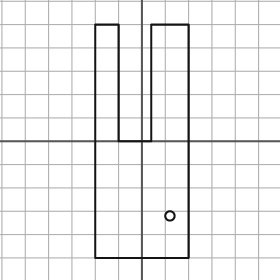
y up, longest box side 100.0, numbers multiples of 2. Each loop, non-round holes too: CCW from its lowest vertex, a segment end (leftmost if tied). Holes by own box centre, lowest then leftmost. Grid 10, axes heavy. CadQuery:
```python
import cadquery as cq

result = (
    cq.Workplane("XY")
    .moveTo(-20.0, -50.0)
    .lineTo(20.0, -50.0)
    .lineTo(20.0, 50.0)
    .lineTo(4.0, 50.0)
    .lineTo(4.0, 0.0)
    .lineTo(-10.0, 0.0)
    .lineTo(-10.0, 50.0)
    .lineTo(-20.0, 50.0)
    .close()
    .moveTo(12.0, -32.0)
    .circle(2.0)
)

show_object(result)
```